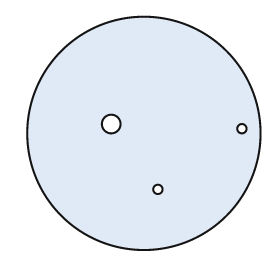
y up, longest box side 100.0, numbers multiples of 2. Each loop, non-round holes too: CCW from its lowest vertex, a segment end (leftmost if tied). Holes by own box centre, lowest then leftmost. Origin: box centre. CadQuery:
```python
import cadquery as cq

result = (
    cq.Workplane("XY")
    .moveTo(0.0, 0.0)
    .circle(50.0)
    .moveTo(6.0, -24.0)
    .circle(2.0)
    .moveTo(42.0, 2.0)
    .circle(2.0)
    .moveTo(-14.0, 4.0)
    .circle(4.0)
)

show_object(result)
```